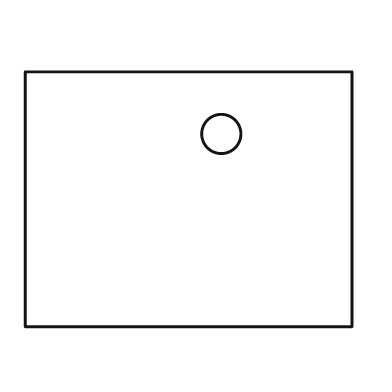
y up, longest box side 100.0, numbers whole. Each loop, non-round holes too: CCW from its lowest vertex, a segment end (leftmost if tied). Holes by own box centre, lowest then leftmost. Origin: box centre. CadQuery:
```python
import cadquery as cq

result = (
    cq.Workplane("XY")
    .moveTo(-50.0, -39.0)
    .lineTo(50.0, -39.0)
    .lineTo(50.0, 39.0)
    .lineTo(-50.0, 39.0)
    .close()
    .moveTo(10.0, 20.0)
    .circle(6.0)
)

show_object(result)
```